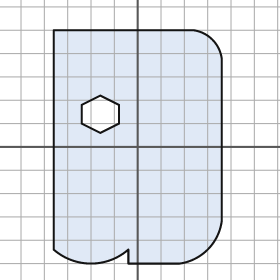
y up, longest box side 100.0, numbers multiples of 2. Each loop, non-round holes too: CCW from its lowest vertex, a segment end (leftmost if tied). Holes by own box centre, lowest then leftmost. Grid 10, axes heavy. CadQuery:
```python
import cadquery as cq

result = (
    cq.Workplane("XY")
    .moveTo(-4.0, -50.0)
    .lineTo(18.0, -50.0)
    .threePointArc((30.0, -44.0), (36.0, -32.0))
    .lineTo(36.0, 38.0)
    .threePointArc((32.0, 46.0), (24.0, 50.0))
    .lineTo(-36.0, 50.0)
    .lineTo(-36.0, -44.0)
    .threePointArc((-20.0, -50.0), (-4.0, -44.0))
    .close()
    .moveTo(-16.0, 6.0)
    .lineTo(-8.0, 10.0)
    .lineTo(-8.0, 18.0)
    .lineTo(-16.0, 22.0)
    .lineTo(-24.0, 18.0)
    .lineTo(-24.0, 10.0)
    .close()
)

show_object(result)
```